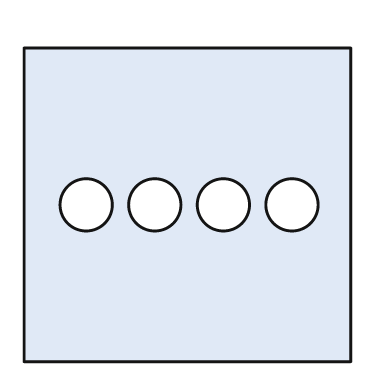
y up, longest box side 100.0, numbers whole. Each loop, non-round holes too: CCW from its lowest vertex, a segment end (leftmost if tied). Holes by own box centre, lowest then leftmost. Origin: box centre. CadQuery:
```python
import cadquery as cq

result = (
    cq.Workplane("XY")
    .moveTo(-50.0, -48.0)
    .lineTo(50.0, -48.0)
    .lineTo(50.0, 48.0)
    .lineTo(-50.0, 48.0)
    .close()
    .moveTo(-31.0, 0.0)
    .circle(8.0)
    .moveTo(-10.0, 0.0)
    .circle(8.0)
    .moveTo(11.0, 0.0)
    .circle(8.0)
    .moveTo(32.0, 0.0)
    .circle(8.0)
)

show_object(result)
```